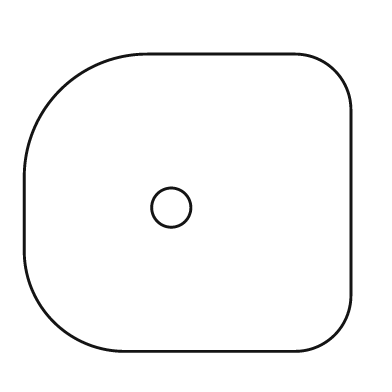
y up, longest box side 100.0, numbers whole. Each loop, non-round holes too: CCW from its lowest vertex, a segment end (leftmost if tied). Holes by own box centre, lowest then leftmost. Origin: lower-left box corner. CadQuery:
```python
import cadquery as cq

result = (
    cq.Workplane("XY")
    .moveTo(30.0, 0.0)
    .lineTo(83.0, 0.0)
    .threePointArc((95.0, 5.0), (100.0, 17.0))
    .lineTo(100.0, 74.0)
    .threePointArc((95.0, 86.0), (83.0, 91.0))
    .lineTo(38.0, 91.0)
    .threePointArc((11.0, 80.0), (0.0, 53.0))
    .lineTo(0.0, 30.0)
    .threePointArc((9.0, 9.0), (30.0, 0.0))
    .close()
    .moveTo(45.0, 44.0)
    .circle(6.0)
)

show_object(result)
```